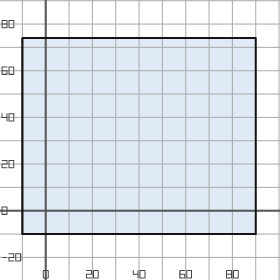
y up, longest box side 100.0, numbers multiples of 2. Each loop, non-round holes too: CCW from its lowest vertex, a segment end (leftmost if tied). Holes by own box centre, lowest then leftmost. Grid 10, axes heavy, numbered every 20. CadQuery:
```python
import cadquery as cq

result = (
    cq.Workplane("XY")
    .moveTo(-10.0, -10.0)
    .lineTo(90.0, -10.0)
    .lineTo(90.0, 74.0)
    .lineTo(-10.0, 74.0)
    .close()
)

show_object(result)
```